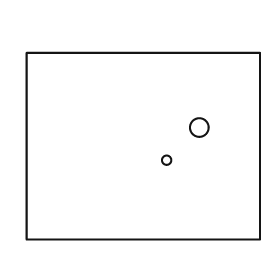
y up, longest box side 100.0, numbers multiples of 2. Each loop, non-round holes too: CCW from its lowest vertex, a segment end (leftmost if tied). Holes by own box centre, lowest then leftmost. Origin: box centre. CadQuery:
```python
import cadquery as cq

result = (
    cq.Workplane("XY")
    .moveTo(-50.0, -40.0)
    .lineTo(50.0, -40.0)
    .lineTo(50.0, 40.0)
    .lineTo(-50.0, 40.0)
    .close()
    .moveTo(10.0, -6.0)
    .circle(2.0)
    .moveTo(24.0, 8.0)
    .circle(4.0)
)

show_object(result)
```